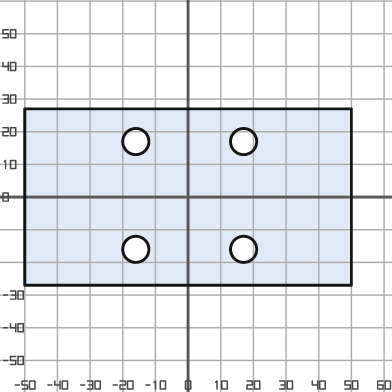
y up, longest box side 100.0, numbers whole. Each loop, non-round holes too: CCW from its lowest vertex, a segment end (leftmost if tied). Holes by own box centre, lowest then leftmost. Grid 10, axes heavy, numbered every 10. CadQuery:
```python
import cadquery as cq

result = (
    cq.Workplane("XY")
    .moveTo(-50.0, -27.0)
    .lineTo(50.0, -27.0)
    .lineTo(50.0, 27.0)
    .lineTo(-50.0, 27.0)
    .close()
    .moveTo(-16.0, -16.0)
    .circle(4.0)
    .moveTo(17.0, -16.0)
    .circle(4.0)
    .moveTo(-16.0, 17.0)
    .circle(4.0)
    .moveTo(17.0, 17.0)
    .circle(4.0)
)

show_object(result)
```